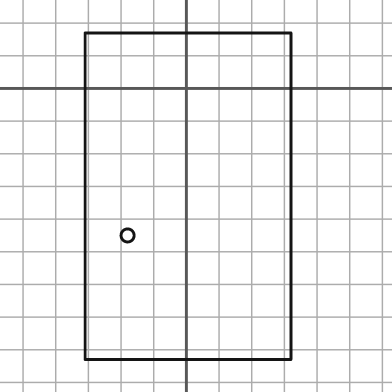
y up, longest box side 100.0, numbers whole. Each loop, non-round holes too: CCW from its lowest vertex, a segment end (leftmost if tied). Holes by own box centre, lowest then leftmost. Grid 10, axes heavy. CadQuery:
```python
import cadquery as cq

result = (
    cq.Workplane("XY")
    .moveTo(-31.0, -83.0)
    .lineTo(32.0, -83.0)
    .lineTo(32.0, 17.0)
    .lineTo(-31.0, 17.0)
    .close()
    .moveTo(-18.0, -45.0)
    .circle(2.0)
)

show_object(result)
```